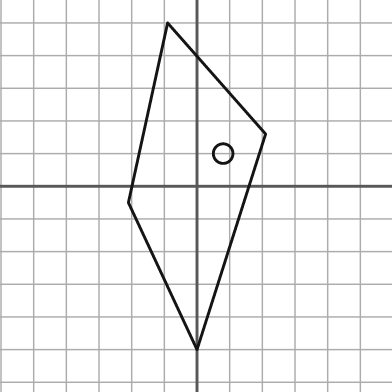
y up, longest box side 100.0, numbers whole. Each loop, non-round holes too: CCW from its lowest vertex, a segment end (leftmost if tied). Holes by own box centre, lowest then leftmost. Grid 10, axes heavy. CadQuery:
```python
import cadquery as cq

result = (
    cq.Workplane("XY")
    .moveTo(0.0, -50.0)
    .lineTo(21.0, 16.0)
    .lineTo(-9.0, 50.0)
    .lineTo(-21.0, -5.0)
    .close()
    .moveTo(8.0, 10.0)
    .circle(3.0)
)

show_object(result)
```